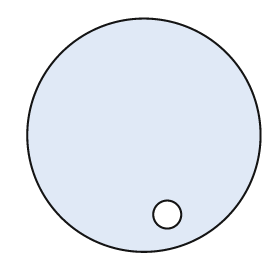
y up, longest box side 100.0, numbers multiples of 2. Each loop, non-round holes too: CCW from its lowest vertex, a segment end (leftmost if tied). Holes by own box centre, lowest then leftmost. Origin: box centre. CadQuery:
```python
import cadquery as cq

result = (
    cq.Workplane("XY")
    .moveTo(0.0, 0.0)
    .circle(50.0)
    .moveTo(10.0, -34.0)
    .circle(6.0)
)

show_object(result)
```